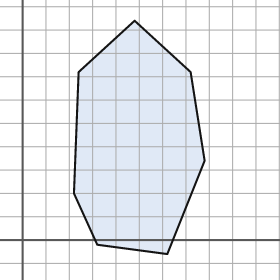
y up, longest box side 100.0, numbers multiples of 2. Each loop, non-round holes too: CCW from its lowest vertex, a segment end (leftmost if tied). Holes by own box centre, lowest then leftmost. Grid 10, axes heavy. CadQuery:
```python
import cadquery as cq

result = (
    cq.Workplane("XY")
    .moveTo(62.0, -6.0)
    .lineTo(78.0, 34.0)
    .lineTo(72.0, 72.0)
    .lineTo(48.0, 94.0)
    .lineTo(24.0, 72.0)
    .lineTo(22.0, 20.0)
    .lineTo(32.0, -2.0)
    .close()
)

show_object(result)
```